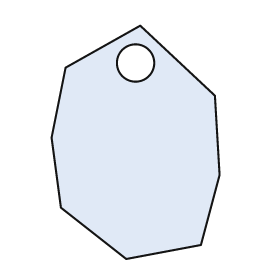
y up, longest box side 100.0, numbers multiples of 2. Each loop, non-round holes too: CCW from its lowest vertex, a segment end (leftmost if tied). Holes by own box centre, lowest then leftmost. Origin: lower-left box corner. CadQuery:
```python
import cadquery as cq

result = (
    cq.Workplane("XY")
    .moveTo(32.0, 0.0)
    .lineTo(64.0, 6.0)
    .lineTo(72.0, 36.0)
    .lineTo(70.0, 70.0)
    .lineTo(38.0, 100.0)
    .lineTo(6.0, 82.0)
    .lineTo(0.0, 52.0)
    .lineTo(4.0, 22.0)
    .close()
    .moveTo(36.0, 84.0)
    .circle(8.0)
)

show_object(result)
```